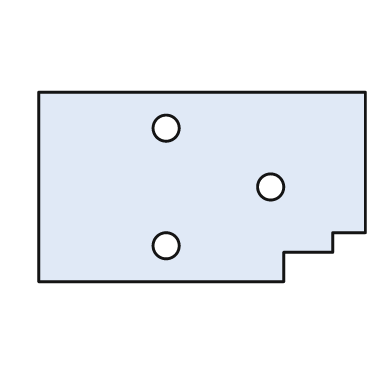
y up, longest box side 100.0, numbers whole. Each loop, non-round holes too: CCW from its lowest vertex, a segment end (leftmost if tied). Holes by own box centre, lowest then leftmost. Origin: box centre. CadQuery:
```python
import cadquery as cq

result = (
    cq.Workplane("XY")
    .moveTo(-50.0, -29.0)
    .lineTo(25.0, -29.0)
    .lineTo(25.0, -20.0)
    .lineTo(40.0, -20.0)
    .lineTo(40.0, -14.0)
    .lineTo(50.0, -14.0)
    .lineTo(50.0, 29.0)
    .lineTo(-50.0, 29.0)
    .close()
    .moveTo(-11.0, -18.0)
    .circle(4.0)
    .moveTo(21.0, 0.0)
    .circle(4.0)
    .moveTo(-11.0, 18.0)
    .circle(4.0)
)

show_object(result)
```